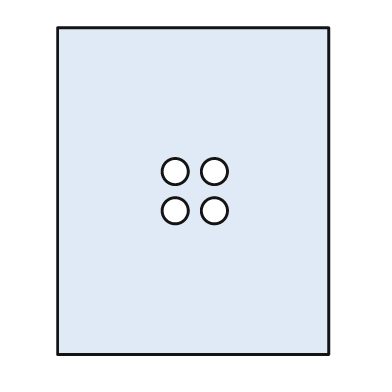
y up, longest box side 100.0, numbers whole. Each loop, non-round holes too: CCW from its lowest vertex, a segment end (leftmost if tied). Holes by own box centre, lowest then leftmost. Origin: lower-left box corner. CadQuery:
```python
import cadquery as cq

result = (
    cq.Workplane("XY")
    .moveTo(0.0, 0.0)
    .lineTo(83.0, 0.0)
    .lineTo(83.0, 100.0)
    .lineTo(0.0, 100.0)
    .close()
    .moveTo(36.0, 44.0)
    .circle(4.0)
    .moveTo(48.0, 44.0)
    .circle(4.0)
    .moveTo(36.0, 56.0)
    .circle(4.0)
    .moveTo(48.0, 56.0)
    .circle(4.0)
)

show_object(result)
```